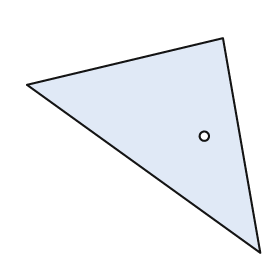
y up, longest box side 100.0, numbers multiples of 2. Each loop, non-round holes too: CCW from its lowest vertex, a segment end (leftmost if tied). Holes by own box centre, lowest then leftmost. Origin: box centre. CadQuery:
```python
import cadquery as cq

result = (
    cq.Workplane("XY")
    .moveTo(50.0, -46.0)
    .lineTo(34.0, 46.0)
    .lineTo(-50.0, 26.0)
    .close()
    .moveTo(26.0, 4.0)
    .circle(2.0)
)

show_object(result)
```